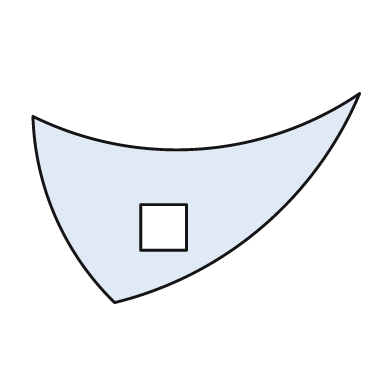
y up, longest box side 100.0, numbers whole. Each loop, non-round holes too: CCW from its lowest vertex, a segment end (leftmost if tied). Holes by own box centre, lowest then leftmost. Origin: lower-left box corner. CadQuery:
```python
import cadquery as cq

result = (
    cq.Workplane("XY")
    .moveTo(25.0, 0.0)
    .threePointArc((70.0, 23.0), (100.0, 64.0))
    .threePointArc((51.0, 47.0), (0.0, 57.0))
    .threePointArc((7.0, 26.0), (25.0, 0.0))
    .close()
    .moveTo(33.0, 16.0)
    .lineTo(47.0, 16.0)
    .lineTo(47.0, 30.0)
    .lineTo(33.0, 30.0)
    .close()
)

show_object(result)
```